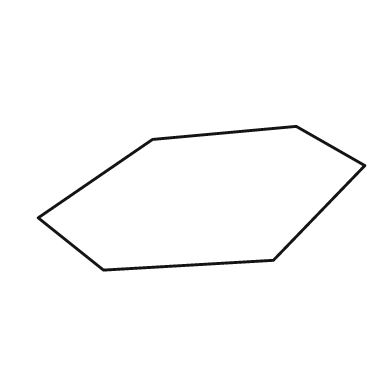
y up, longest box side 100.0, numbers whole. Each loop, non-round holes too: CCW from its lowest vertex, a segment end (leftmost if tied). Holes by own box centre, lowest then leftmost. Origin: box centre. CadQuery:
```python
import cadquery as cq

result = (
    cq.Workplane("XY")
    .moveTo(-30.0, -22.0)
    .lineTo(22.0, -19.0)
    .lineTo(50.0, 10.0)
    .lineTo(29.0, 22.0)
    .lineTo(-15.0, 18.0)
    .lineTo(-50.0, -6.0)
    .close()
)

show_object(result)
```